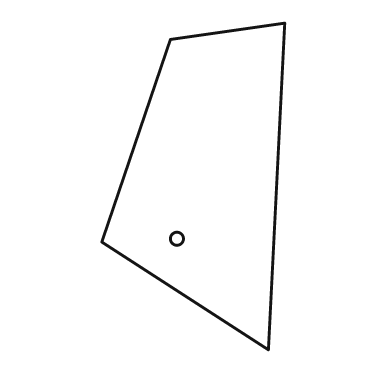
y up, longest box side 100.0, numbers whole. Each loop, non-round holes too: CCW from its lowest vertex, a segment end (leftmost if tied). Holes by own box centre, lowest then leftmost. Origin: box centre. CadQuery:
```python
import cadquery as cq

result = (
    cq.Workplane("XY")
    .moveTo(23.0, -50.0)
    .lineTo(28.0, 50.0)
    .lineTo(-7.0, 45.0)
    .lineTo(-28.0, -17.0)
    .close()
    .moveTo(-5.0, -16.0)
    .circle(2.0)
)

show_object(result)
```